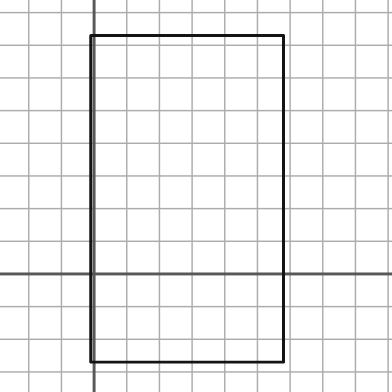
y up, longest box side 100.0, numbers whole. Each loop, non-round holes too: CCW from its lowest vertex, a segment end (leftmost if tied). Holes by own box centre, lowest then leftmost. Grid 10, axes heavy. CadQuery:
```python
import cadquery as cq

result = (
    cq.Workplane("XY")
    .moveTo(-1.0, -27.0)
    .lineTo(58.0, -27.0)
    .lineTo(58.0, 73.0)
    .lineTo(-1.0, 73.0)
    .close()
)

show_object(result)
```